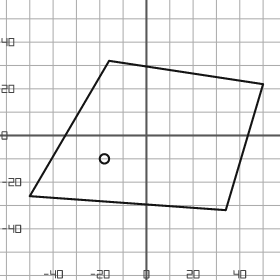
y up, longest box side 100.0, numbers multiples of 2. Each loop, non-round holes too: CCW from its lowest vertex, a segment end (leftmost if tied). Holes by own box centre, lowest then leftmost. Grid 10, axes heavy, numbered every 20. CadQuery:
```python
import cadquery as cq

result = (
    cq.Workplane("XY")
    .moveTo(34.0, -32.0)
    .lineTo(50.0, 22.0)
    .lineTo(-16.0, 32.0)
    .lineTo(-50.0, -26.0)
    .close()
    .moveTo(-18.0, -10.0)
    .circle(2.0)
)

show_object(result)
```